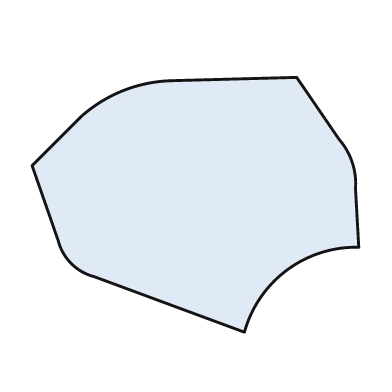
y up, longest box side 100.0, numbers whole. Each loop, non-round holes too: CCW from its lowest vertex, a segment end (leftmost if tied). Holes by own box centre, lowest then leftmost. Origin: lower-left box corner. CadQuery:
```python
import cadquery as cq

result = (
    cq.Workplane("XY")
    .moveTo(65.0, 0.0)
    .threePointArc((78.0, 19.0), (100.0, 26.0))
    .lineTo(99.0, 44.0)
    .threePointArc((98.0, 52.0), (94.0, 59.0))
    .lineTo(81.0, 78.0)
    .lineTo(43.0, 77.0)
    .threePointArc((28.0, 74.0), (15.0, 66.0))
    .lineTo(0.0, 51.0)
    .lineTo(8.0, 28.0)
    .threePointArc((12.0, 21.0), (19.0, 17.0))
    .close()
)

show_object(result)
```